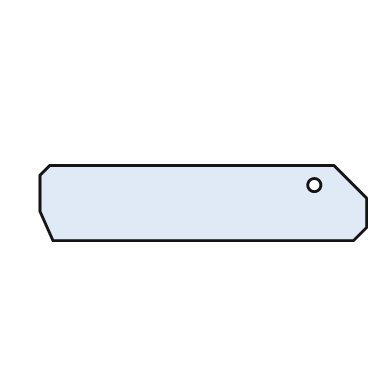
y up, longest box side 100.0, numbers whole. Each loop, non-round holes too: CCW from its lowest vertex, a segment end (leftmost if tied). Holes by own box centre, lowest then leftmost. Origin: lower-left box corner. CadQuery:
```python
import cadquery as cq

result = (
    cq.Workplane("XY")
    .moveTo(4.0, 0.0)
    .lineTo(96.0, 0.0)
    .lineTo(100.0, 4.0)
    .lineTo(100.0, 13.0)
    .lineTo(90.0, 23.0)
    .lineTo(3.0, 23.0)
    .lineTo(0.0, 20.0)
    .lineTo(0.0, 9.0)
    .close()
    .moveTo(84.0, 17.0)
    .circle(2.0)
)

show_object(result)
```